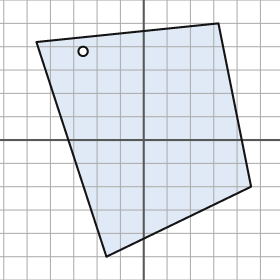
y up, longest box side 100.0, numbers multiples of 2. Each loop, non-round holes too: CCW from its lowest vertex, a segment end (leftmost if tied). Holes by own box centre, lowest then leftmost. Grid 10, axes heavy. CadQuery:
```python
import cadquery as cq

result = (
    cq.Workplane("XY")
    .moveTo(-16.0, -50.0)
    .lineTo(46.0, -20.0)
    .lineTo(32.0, 50.0)
    .lineTo(-46.0, 42.0)
    .close()
    .moveTo(-26.0, 38.0)
    .circle(2.0)
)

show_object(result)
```